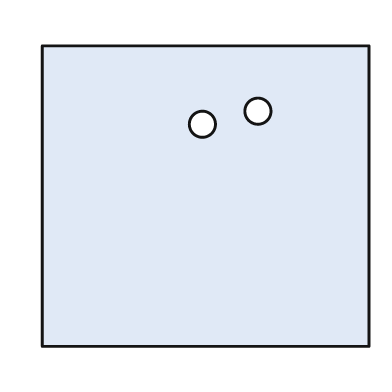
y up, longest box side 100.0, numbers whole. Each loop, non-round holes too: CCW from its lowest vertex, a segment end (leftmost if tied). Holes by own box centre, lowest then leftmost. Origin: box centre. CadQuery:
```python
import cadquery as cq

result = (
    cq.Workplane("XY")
    .moveTo(-50.0, -46.0)
    .lineTo(50.0, -46.0)
    .lineTo(50.0, 46.0)
    .lineTo(-50.0, 46.0)
    .close()
    .moveTo(-1.0, 22.0)
    .circle(4.0)
    .moveTo(16.0, 26.0)
    .circle(4.0)
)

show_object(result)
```